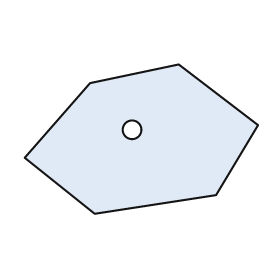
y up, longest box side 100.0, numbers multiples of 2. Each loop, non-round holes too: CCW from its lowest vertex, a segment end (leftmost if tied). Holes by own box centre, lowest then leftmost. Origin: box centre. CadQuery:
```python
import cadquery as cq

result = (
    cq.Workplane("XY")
    .moveTo(-20.0, -32.0)
    .lineTo(32.0, -24.0)
    .lineTo(50.0, 6.0)
    .lineTo(16.0, 32.0)
    .lineTo(-22.0, 24.0)
    .lineTo(-50.0, -8.0)
    .close()
    .moveTo(-4.0, 4.0)
    .circle(4.0)
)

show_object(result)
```